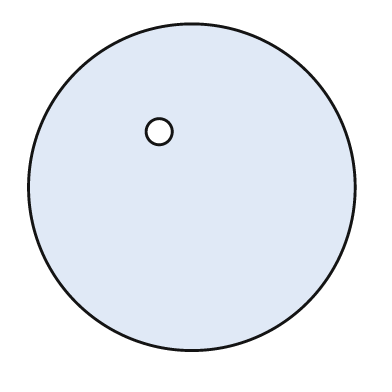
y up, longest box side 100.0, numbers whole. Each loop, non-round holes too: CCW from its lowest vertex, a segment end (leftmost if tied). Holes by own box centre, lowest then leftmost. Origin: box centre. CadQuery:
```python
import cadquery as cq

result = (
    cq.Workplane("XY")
    .moveTo(0.0, 0.0)
    .circle(50.0)
    .moveTo(-10.0, 17.0)
    .circle(4.0)
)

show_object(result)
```